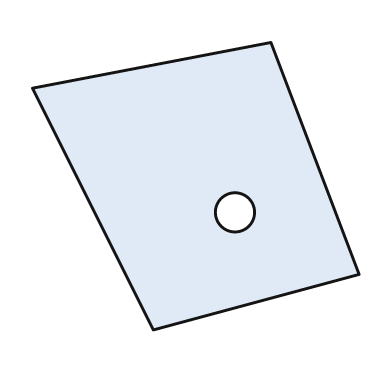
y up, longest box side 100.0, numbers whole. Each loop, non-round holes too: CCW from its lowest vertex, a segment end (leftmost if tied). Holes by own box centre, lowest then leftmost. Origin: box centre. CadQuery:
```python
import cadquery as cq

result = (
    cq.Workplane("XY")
    .moveTo(-13.0, -44.0)
    .lineTo(50.0, -27.0)
    .lineTo(23.0, 44.0)
    .lineTo(-50.0, 30.0)
    .close()
    .moveTo(12.0, -8.0)
    .circle(6.0)
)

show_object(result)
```